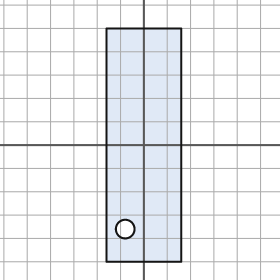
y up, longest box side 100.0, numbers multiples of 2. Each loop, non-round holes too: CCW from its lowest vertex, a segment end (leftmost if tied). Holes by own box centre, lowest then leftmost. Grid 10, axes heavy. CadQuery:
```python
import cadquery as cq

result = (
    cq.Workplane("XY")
    .moveTo(-16.0, -50.0)
    .lineTo(16.0, -50.0)
    .lineTo(16.0, 50.0)
    .lineTo(-16.0, 50.0)
    .close()
    .moveTo(-8.0, -36.0)
    .circle(4.0)
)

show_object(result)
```